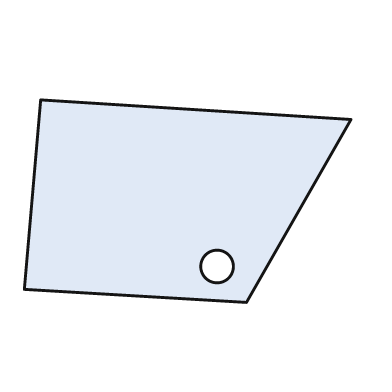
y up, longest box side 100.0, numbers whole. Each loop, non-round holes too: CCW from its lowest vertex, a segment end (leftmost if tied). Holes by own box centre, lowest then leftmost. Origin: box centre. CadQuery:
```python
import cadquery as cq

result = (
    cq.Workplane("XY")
    .moveTo(18.0, -31.0)
    .lineTo(50.0, 25.0)
    .lineTo(-45.0, 31.0)
    .lineTo(-50.0, -27.0)
    .close()
    .moveTo(9.0, -20.0)
    .circle(5.0)
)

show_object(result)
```